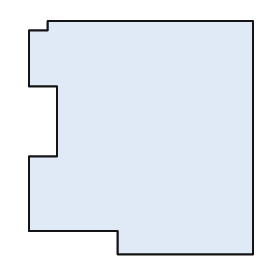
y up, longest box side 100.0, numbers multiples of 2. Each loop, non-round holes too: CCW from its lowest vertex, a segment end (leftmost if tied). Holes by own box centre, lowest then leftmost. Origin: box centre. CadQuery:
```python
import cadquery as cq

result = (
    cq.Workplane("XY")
    .moveTo(-10.0, -50.0)
    .lineTo(48.0, -50.0)
    .lineTo(48.0, 50.0)
    .lineTo(-40.0, 50.0)
    .lineTo(-40.0, 46.0)
    .lineTo(-48.0, 46.0)
    .lineTo(-48.0, 22.0)
    .lineTo(-36.0, 22.0)
    .lineTo(-36.0, -8.0)
    .lineTo(-48.0, -8.0)
    .lineTo(-48.0, -40.0)
    .lineTo(-10.0, -40.0)
    .close()
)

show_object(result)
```